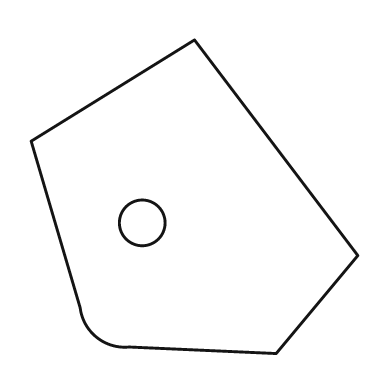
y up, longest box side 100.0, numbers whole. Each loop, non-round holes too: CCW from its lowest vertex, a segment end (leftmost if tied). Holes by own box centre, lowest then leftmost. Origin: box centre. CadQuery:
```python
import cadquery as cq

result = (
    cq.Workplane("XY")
    .moveTo(25.0, -48.0)
    .lineTo(50.0, -18.0)
    .lineTo(0.0, 48.0)
    .lineTo(-50.0, 17.0)
    .lineTo(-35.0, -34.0)
    .threePointArc((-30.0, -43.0), (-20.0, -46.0))
    .close()
    .moveTo(-16.0, -8.0)
    .circle(7.0)
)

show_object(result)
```